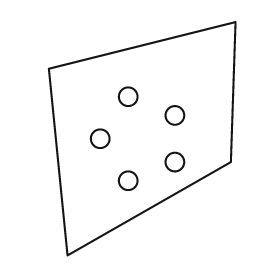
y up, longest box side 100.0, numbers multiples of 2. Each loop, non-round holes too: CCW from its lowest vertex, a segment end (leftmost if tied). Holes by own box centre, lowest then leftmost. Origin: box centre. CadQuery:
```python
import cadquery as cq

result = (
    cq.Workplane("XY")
    .moveTo(-32.0, -50.0)
    .lineTo(38.0, -10.0)
    .lineTo(40.0, 50.0)
    .lineTo(-40.0, 30.0)
    .close()
    .moveTo(-6.0, -18.0)
    .circle(4.0)
    .moveTo(14.0, -10.0)
    .circle(4.0)
    .moveTo(-18.0, 0.0)
    .circle(4.0)
    .moveTo(14.0, 10.0)
    .circle(4.0)
    .moveTo(-6.0, 18.0)
    .circle(4.0)
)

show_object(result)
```